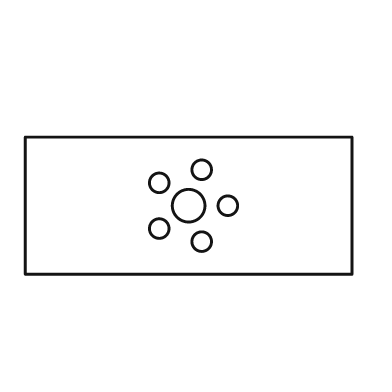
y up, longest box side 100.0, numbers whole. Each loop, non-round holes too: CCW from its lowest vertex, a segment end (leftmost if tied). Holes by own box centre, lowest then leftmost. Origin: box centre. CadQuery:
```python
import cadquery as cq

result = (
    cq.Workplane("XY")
    .moveTo(-50.0, -21.0)
    .lineTo(50.0, -21.0)
    .lineTo(50.0, 21.0)
    .lineTo(-50.0, 21.0)
    .close()
    .moveTo(4.0, -11.0)
    .circle(3.0)
    .moveTo(-9.0, -7.0)
    .circle(3.0)
    .moveTo(0.0, 0.0)
    .circle(5.0)
    .moveTo(12.0, 0.0)
    .circle(3.0)
    .moveTo(-9.0, 7.0)
    .circle(3.0)
    .moveTo(4.0, 11.0)
    .circle(3.0)
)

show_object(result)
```